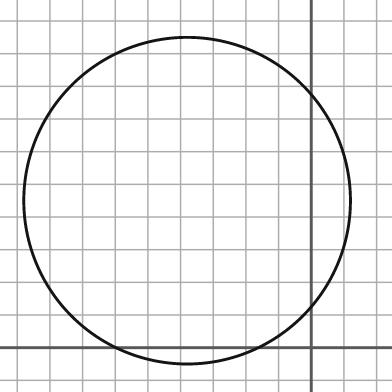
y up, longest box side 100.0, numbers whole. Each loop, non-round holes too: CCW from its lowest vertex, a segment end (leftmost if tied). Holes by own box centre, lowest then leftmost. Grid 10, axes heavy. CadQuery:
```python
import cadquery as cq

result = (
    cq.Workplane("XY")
    .moveTo(-38.0, 45.0)
    .circle(50.0)
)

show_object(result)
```